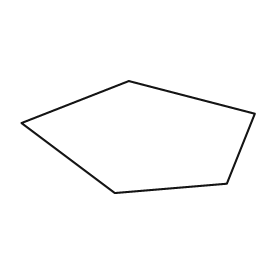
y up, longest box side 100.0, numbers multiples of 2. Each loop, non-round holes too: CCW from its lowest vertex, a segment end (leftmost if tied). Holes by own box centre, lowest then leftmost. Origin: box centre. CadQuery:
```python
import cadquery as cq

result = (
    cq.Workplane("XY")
    .moveTo(-10.0, -24.0)
    .lineTo(38.0, -20.0)
    .lineTo(50.0, 10.0)
    .lineTo(-4.0, 24.0)
    .lineTo(-50.0, 6.0)
    .close()
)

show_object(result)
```